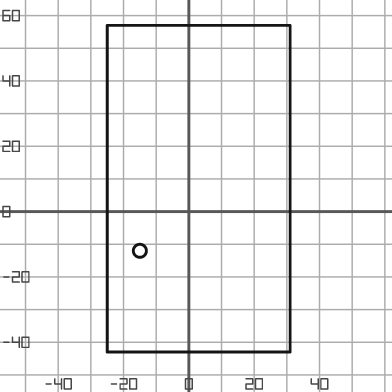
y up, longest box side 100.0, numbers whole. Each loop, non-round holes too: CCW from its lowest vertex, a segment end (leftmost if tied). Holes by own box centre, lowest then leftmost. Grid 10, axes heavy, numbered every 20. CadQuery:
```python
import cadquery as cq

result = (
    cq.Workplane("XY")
    .moveTo(-25.0, -43.0)
    .lineTo(31.0, -43.0)
    .lineTo(31.0, 57.0)
    .lineTo(-25.0, 57.0)
    .close()
    .moveTo(-15.0, -12.0)
    .circle(2.0)
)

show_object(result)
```